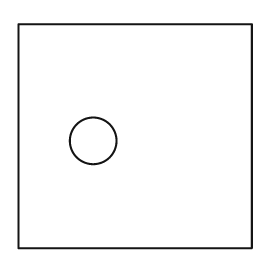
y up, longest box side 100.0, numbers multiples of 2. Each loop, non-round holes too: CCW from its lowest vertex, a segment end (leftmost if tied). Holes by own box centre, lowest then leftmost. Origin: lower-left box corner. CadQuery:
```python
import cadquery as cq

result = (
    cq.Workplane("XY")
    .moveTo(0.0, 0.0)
    .lineTo(100.0, 0.0)
    .lineTo(100.0, 96.0)
    .lineTo(0.0, 96.0)
    .close()
    .moveTo(32.0, 46.0)
    .circle(10.0)
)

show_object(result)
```